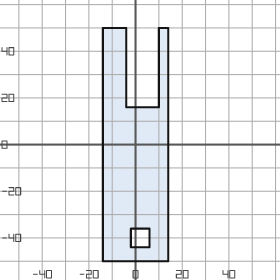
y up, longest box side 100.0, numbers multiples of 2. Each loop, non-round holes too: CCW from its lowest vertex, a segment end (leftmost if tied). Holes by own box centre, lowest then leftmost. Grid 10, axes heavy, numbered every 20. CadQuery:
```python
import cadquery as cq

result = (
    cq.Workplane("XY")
    .moveTo(-14.0, -50.0)
    .lineTo(14.0, -50.0)
    .lineTo(14.0, 50.0)
    .lineTo(10.0, 50.0)
    .lineTo(10.0, 16.0)
    .lineTo(-4.0, 16.0)
    .lineTo(-4.0, 50.0)
    .lineTo(-14.0, 50.0)
    .close()
    .moveTo(-2.0, -44.0)
    .lineTo(6.0, -44.0)
    .lineTo(6.0, -36.0)
    .lineTo(-2.0, -36.0)
    .close()
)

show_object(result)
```